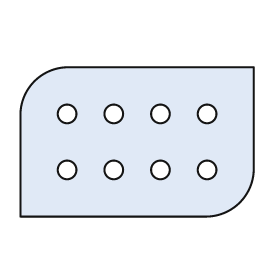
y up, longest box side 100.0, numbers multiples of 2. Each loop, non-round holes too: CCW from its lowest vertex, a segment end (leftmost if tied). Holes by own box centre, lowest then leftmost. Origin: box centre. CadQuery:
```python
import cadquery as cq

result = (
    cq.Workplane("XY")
    .moveTo(-50.0, -32.0)
    .lineTo(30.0, -32.0)
    .threePointArc((44.0, -26.0), (50.0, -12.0))
    .lineTo(50.0, 32.0)
    .lineTo(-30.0, 32.0)
    .threePointArc((-44.0, 26.0), (-50.0, 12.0))
    .close()
    .moveTo(-30.0, -12.0)
    .circle(4.0)
    .moveTo(-10.0, -12.0)
    .circle(4.0)
    .moveTo(10.0, -12.0)
    .circle(4.0)
    .moveTo(30.0, -12.0)
    .circle(4.0)
    .moveTo(-30.0, 12.0)
    .circle(4.0)
    .moveTo(-10.0, 12.0)
    .circle(4.0)
    .moveTo(10.0, 12.0)
    .circle(4.0)
    .moveTo(30.0, 12.0)
    .circle(4.0)
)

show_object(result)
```